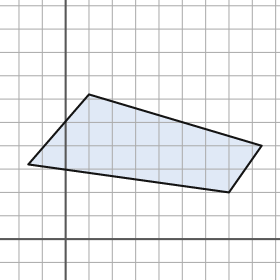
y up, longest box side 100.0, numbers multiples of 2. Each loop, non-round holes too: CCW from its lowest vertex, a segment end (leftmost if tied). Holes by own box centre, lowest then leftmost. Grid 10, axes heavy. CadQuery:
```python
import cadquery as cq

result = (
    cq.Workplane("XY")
    .moveTo(70.0, 20.0)
    .lineTo(84.0, 40.0)
    .lineTo(10.0, 62.0)
    .lineTo(-16.0, 32.0)
    .close()
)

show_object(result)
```